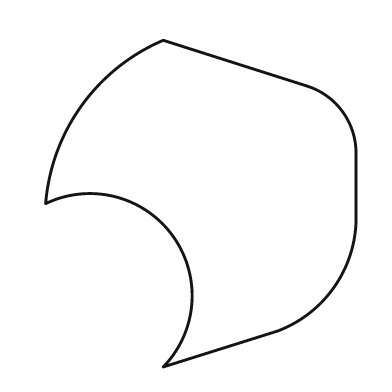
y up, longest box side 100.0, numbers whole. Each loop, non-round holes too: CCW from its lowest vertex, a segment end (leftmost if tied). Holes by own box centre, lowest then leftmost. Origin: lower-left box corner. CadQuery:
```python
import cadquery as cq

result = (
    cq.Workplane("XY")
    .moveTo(36.0, 0.0)
    .lineTo(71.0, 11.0)
    .threePointArc((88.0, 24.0), (95.0, 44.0))
    .lineTo(95.0, 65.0)
    .threePointArc((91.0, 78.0), (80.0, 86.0))
    .lineTo(36.0, 100.0)
    .threePointArc((11.0, 80.0), (0.0, 50.0))
    .threePointArc((39.0, 40.0), (36.0, 0.0))
    .close()
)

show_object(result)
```